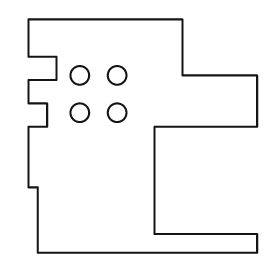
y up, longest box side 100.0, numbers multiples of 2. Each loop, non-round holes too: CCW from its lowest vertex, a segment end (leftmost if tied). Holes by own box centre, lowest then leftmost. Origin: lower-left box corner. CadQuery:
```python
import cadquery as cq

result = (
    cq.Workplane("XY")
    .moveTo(4.0, 0.0)
    .lineTo(98.0, 0.0)
    .lineTo(98.0, 8.0)
    .lineTo(54.0, 8.0)
    .lineTo(54.0, 54.0)
    .lineTo(98.0, 54.0)
    .lineTo(98.0, 76.0)
    .lineTo(66.0, 76.0)
    .lineTo(66.0, 100.0)
    .lineTo(0.0, 100.0)
    .lineTo(0.0, 84.0)
    .lineTo(12.0, 84.0)
    .lineTo(12.0, 74.0)
    .lineTo(0.0, 74.0)
    .lineTo(0.0, 64.0)
    .lineTo(8.0, 64.0)
    .lineTo(8.0, 54.0)
    .lineTo(0.0, 54.0)
    .lineTo(0.0, 28.0)
    .lineTo(4.0, 28.0)
    .close()
    .moveTo(22.0, 60.0)
    .circle(4.0)
    .moveTo(38.0, 60.0)
    .circle(4.0)
    .moveTo(22.0, 76.0)
    .circle(4.0)
    .moveTo(38.0, 76.0)
    .circle(4.0)
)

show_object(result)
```